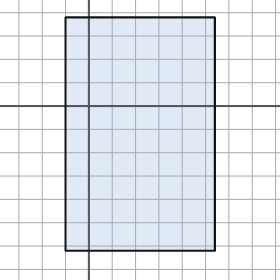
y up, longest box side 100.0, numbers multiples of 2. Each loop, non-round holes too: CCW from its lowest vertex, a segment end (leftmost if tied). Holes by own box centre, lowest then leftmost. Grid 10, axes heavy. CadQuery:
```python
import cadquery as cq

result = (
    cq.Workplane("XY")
    .moveTo(-10.0, -62.0)
    .lineTo(54.0, -62.0)
    .lineTo(54.0, 38.0)
    .lineTo(-10.0, 38.0)
    .close()
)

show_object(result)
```